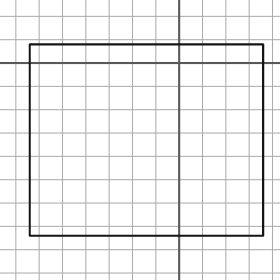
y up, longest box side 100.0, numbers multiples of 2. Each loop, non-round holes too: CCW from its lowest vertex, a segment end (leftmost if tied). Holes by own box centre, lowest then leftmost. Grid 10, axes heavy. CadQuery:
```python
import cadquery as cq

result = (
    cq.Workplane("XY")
    .moveTo(-64.0, -74.0)
    .lineTo(36.0, -74.0)
    .lineTo(36.0, 8.0)
    .lineTo(-64.0, 8.0)
    .close()
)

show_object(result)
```